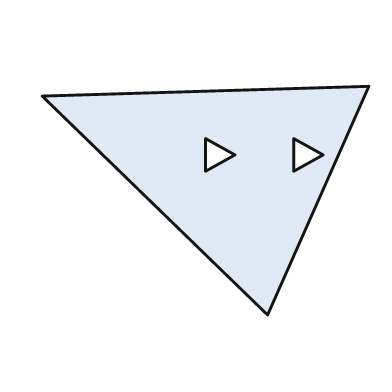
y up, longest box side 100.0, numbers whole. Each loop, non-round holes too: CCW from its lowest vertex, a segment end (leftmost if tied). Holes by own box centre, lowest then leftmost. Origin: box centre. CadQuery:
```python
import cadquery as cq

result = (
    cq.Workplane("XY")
    .moveTo(19.0, -35.0)
    .lineTo(50.0, 35.0)
    .lineTo(-50.0, 32.0)
    .close()
    .moveTo(0.0, 9.0)
    .lineTo(9.0, 14.0)
    .lineTo(0.0, 19.0)
    .close()
    .moveTo(27.0, 9.0)
    .lineTo(36.0, 14.0)
    .lineTo(27.0, 19.0)
    .close()
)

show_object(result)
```